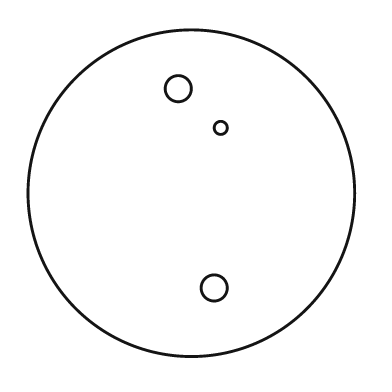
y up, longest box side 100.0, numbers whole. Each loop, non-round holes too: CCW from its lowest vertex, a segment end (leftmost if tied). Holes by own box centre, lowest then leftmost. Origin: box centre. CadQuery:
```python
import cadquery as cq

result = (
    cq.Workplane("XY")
    .moveTo(0.0, 0.0)
    .circle(50.0)
    .moveTo(7.0, -29.0)
    .circle(4.0)
    .moveTo(9.0, 20.0)
    .circle(2.0)
    .moveTo(-4.0, 32.0)
    .circle(4.0)
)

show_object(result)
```